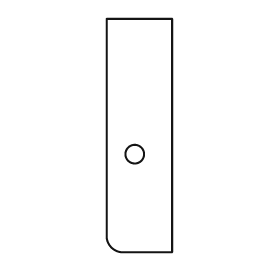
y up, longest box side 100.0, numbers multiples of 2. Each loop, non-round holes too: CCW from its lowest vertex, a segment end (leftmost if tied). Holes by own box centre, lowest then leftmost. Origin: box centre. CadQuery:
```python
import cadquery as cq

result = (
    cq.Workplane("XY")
    .moveTo(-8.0, -50.0)
    .lineTo(14.0, -50.0)
    .lineTo(14.0, 50.0)
    .lineTo(-14.0, 50.0)
    .lineTo(-14.0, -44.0)
    .threePointArc((-12.0, -48.0), (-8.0, -50.0))
    .close()
    .moveTo(-2.0, -8.0)
    .circle(4.0)
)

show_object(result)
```